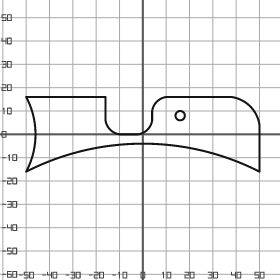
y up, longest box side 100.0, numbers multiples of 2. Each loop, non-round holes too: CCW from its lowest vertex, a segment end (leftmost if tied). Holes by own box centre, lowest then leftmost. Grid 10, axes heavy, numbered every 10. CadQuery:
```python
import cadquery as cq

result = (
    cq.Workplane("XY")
    .moveTo(-50.0, -16.0)
    .threePointArc((0.0, -4.0), (50.0, -16.0))
    .lineTo(50.0, 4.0)
    .threePointArc((46.0, 12.0), (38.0, 16.0))
    .lineTo(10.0, 16.0)
    .threePointArc((6.0, 14.0), (4.0, 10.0))
    .lineTo(4.0, 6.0)
    .threePointArc((2.0, 2.0), (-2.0, 0.0))
    .lineTo(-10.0, 0.0)
    .threePointArc((-14.0, 2.0), (-16.0, 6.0))
    .lineTo(-16.0, 16.0)
    .lineTo(-50.0, 16.0)
    .threePointArc((-46.0, 0.0), (-50.0, -16.0))
    .close()
    .moveTo(16.0, 8.0)
    .circle(2.0)
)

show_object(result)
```